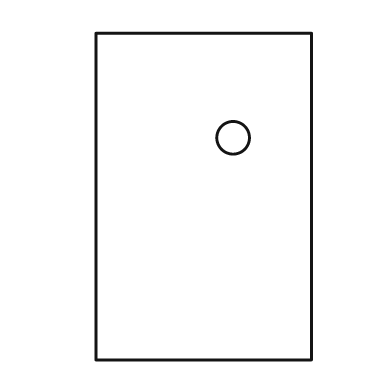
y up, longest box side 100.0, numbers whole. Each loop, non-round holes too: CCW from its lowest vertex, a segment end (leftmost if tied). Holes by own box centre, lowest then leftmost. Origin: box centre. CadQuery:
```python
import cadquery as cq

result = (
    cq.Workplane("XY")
    .moveTo(-33.0, -50.0)
    .lineTo(33.0, -50.0)
    .lineTo(33.0, 50.0)
    .lineTo(-33.0, 50.0)
    .close()
    .moveTo(9.0, 18.0)
    .circle(5.0)
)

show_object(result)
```